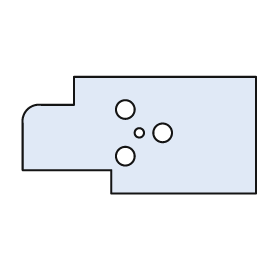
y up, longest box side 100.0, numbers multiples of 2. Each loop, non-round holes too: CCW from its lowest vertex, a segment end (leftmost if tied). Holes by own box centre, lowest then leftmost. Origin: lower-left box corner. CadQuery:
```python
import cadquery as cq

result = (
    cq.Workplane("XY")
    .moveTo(38.0, 0.0)
    .lineTo(100.0, 0.0)
    .lineTo(100.0, 50.0)
    .lineTo(22.0, 50.0)
    .lineTo(22.0, 38.0)
    .lineTo(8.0, 38.0)
    .threePointArc((2.0, 36.0), (0.0, 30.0))
    .lineTo(0.0, 10.0)
    .lineTo(38.0, 10.0)
    .close()
    .moveTo(44.0, 16.0)
    .circle(4.0)
    .moveTo(50.0, 26.0)
    .circle(2.0)
    .moveTo(60.0, 26.0)
    .circle(4.0)
    .moveTo(44.0, 36.0)
    .circle(4.0)
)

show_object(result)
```